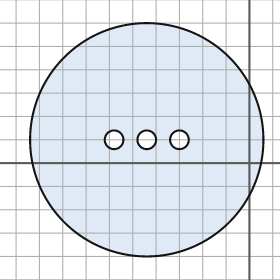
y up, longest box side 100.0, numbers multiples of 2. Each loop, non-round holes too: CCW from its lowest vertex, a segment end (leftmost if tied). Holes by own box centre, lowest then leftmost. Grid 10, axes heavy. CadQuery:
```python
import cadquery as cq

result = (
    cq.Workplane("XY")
    .moveTo(-44.0, 10.0)
    .circle(50.0)
    .moveTo(-58.0, 10.0)
    .circle(4.0)
    .moveTo(-44.0, 10.0)
    .circle(4.0)
    .moveTo(-30.0, 10.0)
    .circle(4.0)
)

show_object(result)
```